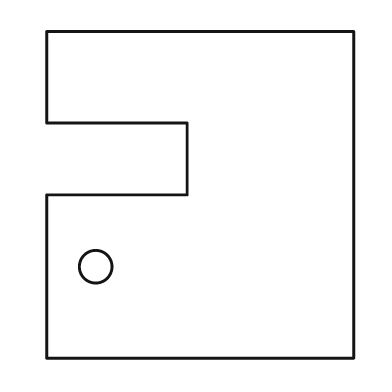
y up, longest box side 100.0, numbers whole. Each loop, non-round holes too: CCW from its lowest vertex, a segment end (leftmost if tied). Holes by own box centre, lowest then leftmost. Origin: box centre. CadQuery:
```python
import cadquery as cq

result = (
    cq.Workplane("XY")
    .moveTo(-47.0, -50.0)
    .lineTo(47.0, -50.0)
    .lineTo(47.0, 50.0)
    .lineTo(-47.0, 50.0)
    .lineTo(-47.0, 22.0)
    .lineTo(-4.0, 22.0)
    .lineTo(-4.0, 0.0)
    .lineTo(-47.0, 0.0)
    .close()
    .moveTo(-32.0, -22.0)
    .circle(5.0)
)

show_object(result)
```